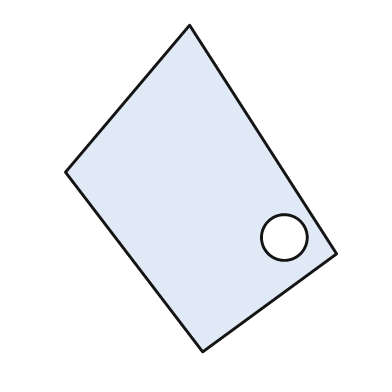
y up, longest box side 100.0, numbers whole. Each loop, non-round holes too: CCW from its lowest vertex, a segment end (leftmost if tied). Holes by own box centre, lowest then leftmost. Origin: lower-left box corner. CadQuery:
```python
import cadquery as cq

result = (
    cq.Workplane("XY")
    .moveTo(42.0, 0.0)
    .lineTo(83.0, 30.0)
    .lineTo(38.0, 100.0)
    .lineTo(0.0, 55.0)
    .close()
    .moveTo(67.0, 35.0)
    .circle(7.0)
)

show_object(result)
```